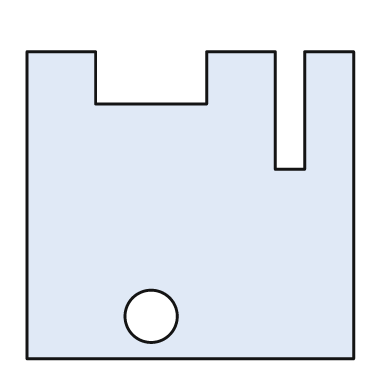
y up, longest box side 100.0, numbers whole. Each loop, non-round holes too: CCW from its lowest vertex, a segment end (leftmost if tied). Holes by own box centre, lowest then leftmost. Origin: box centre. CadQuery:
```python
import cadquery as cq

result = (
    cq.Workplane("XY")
    .moveTo(-50.0, -47.0)
    .lineTo(50.0, -47.0)
    .lineTo(50.0, 47.0)
    .lineTo(35.0, 47.0)
    .lineTo(35.0, 11.0)
    .lineTo(26.0, 11.0)
    .lineTo(26.0, 47.0)
    .lineTo(5.0, 47.0)
    .lineTo(5.0, 31.0)
    .lineTo(-29.0, 31.0)
    .lineTo(-29.0, 47.0)
    .lineTo(-50.0, 47.0)
    .close()
    .moveTo(-12.0, -34.0)
    .circle(8.0)
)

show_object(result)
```